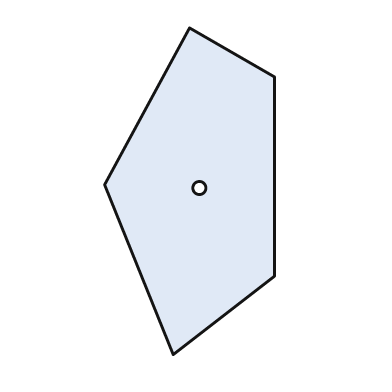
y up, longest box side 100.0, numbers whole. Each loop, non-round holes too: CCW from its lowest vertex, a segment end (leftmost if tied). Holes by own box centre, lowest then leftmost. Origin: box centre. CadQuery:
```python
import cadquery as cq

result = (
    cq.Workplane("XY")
    .moveTo(-5.0, -50.0)
    .lineTo(26.0, -26.0)
    .lineTo(26.0, 35.0)
    .lineTo(0.0, 50.0)
    .lineTo(-26.0, 2.0)
    .close()
    .moveTo(3.0, 1.0)
    .circle(2.0)
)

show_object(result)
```